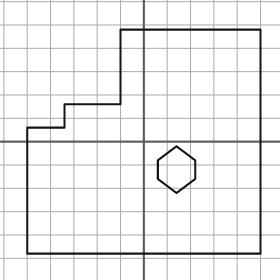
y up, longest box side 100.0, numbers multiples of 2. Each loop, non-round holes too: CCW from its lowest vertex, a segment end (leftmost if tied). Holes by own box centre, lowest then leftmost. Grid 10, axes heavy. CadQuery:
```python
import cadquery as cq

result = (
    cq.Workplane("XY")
    .moveTo(-50.0, -48.0)
    .lineTo(50.0, -48.0)
    .lineTo(50.0, 48.0)
    .lineTo(-10.0, 48.0)
    .lineTo(-10.0, 16.0)
    .lineTo(-34.0, 16.0)
    .lineTo(-34.0, 6.0)
    .lineTo(-50.0, 6.0)
    .close()
    .moveTo(14.0, -22.0)
    .lineTo(22.0, -16.0)
    .lineTo(22.0, -8.0)
    .lineTo(14.0, -2.0)
    .lineTo(6.0, -8.0)
    .lineTo(6.0, -16.0)
    .close()
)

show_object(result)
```